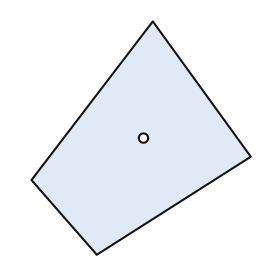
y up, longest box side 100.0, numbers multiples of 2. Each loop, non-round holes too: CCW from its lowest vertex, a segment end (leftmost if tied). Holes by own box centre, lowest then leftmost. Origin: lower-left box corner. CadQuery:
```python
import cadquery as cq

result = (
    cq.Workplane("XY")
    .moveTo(28.0, 0.0)
    .lineTo(94.0, 42.0)
    .lineTo(52.0, 100.0)
    .lineTo(0.0, 32.0)
    .close()
    .moveTo(48.0, 50.0)
    .circle(2.0)
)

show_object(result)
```